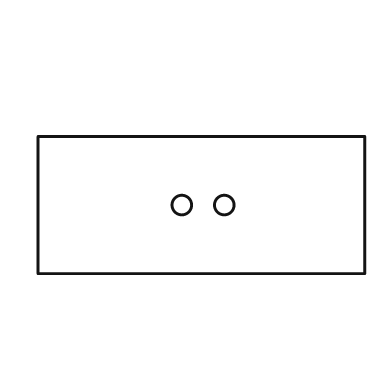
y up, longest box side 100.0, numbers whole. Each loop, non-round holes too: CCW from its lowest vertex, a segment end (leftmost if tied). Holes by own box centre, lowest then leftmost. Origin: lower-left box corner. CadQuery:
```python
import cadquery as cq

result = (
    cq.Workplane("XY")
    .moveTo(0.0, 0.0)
    .lineTo(100.0, 0.0)
    .lineTo(100.0, 42.0)
    .lineTo(0.0, 42.0)
    .close()
    .moveTo(44.0, 21.0)
    .circle(3.0)
    .moveTo(57.0, 21.0)
    .circle(3.0)
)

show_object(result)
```